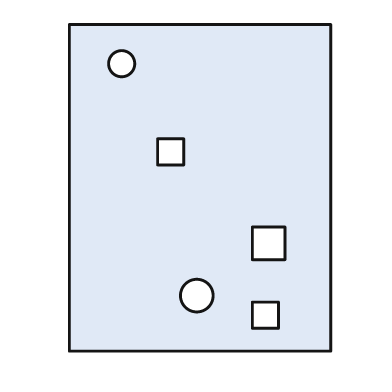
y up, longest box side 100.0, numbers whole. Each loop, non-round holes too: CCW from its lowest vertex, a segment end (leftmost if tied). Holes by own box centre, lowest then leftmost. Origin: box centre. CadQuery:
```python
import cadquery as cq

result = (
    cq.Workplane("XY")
    .moveTo(-40.0, -50.0)
    .lineTo(40.0, -50.0)
    .lineTo(40.0, 50.0)
    .lineTo(-40.0, 50.0)
    .close()
    .moveTo(16.0, -43.0)
    .lineTo(24.0, -43.0)
    .lineTo(24.0, -35.0)
    .lineTo(16.0, -35.0)
    .close()
    .moveTo(-1.0, -33.0)
    .circle(5.0)
    .moveTo(16.0, -22.0)
    .lineTo(26.0, -22.0)
    .lineTo(26.0, -12.0)
    .lineTo(16.0, -12.0)
    .close()
    .moveTo(-13.0, 7.0)
    .lineTo(-5.0, 7.0)
    .lineTo(-5.0, 15.0)
    .lineTo(-13.0, 15.0)
    .close()
    .moveTo(-24.0, 38.0)
    .circle(4.0)
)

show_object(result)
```